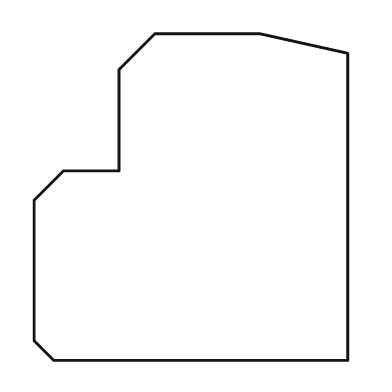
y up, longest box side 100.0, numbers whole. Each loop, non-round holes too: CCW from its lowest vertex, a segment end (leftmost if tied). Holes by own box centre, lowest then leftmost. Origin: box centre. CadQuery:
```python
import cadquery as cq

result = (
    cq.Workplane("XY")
    .moveTo(-42.0, -50.0)
    .lineTo(48.0, -50.0)
    .lineTo(48.0, 44.0)
    .lineTo(21.0, 50.0)
    .lineTo(-11.0, 50.0)
    .lineTo(-22.0, 39.0)
    .lineTo(-22.0, 8.0)
    .lineTo(-39.0, 8.0)
    .lineTo(-48.0, -1.0)
    .lineTo(-48.0, -44.0)
    .close()
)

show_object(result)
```